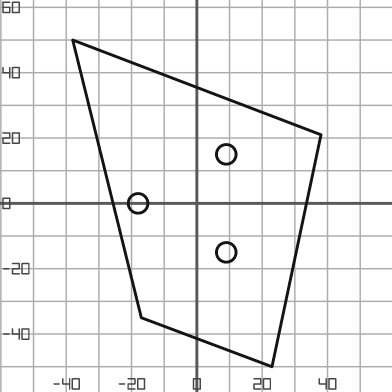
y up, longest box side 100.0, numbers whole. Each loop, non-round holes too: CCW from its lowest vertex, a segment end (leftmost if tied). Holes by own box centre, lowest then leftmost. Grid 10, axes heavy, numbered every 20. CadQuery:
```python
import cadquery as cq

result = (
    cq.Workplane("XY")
    .moveTo(23.0, -50.0)
    .lineTo(38.0, 21.0)
    .lineTo(-38.0, 50.0)
    .lineTo(-17.0, -35.0)
    .close()
    .moveTo(9.0, -15.0)
    .circle(3.0)
    .moveTo(-18.0, 0.0)
    .circle(3.0)
    .moveTo(9.0, 15.0)
    .circle(3.0)
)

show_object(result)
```